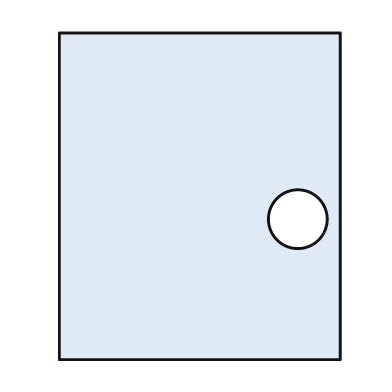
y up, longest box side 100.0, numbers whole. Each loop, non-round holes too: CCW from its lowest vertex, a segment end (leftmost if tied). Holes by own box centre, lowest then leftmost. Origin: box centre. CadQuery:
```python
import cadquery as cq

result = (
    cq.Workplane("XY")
    .moveTo(-43.0, -50.0)
    .lineTo(43.0, -50.0)
    .lineTo(43.0, 50.0)
    .lineTo(-43.0, 50.0)
    .close()
    .moveTo(30.0, -7.0)
    .circle(9.0)
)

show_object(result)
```